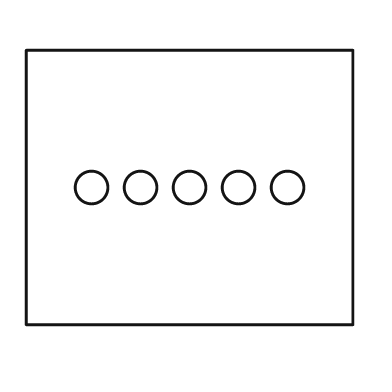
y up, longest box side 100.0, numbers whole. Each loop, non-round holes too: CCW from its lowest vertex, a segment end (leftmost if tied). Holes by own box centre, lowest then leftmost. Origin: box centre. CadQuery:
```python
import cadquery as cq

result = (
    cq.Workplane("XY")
    .moveTo(-50.0, -42.0)
    .lineTo(50.0, -42.0)
    .lineTo(50.0, 42.0)
    .lineTo(-50.0, 42.0)
    .close()
    .moveTo(-30.0, 0.0)
    .circle(5.0)
    .moveTo(-15.0, 0.0)
    .circle(5.0)
    .moveTo(0.0, 0.0)
    .circle(5.0)
    .moveTo(15.0, 0.0)
    .circle(5.0)
    .moveTo(30.0, 0.0)
    .circle(5.0)
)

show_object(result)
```